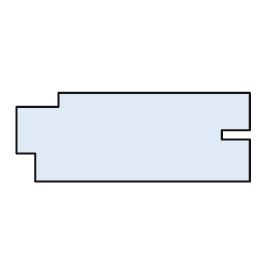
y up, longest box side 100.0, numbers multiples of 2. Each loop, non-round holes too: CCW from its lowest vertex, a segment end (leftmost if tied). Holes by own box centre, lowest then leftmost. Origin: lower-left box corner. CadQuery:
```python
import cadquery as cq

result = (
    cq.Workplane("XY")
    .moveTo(8.0, 0.0)
    .lineTo(100.0, 0.0)
    .lineTo(100.0, 18.0)
    .lineTo(88.0, 18.0)
    .lineTo(88.0, 22.0)
    .lineTo(100.0, 22.0)
    .lineTo(100.0, 38.0)
    .lineTo(18.0, 38.0)
    .lineTo(18.0, 32.0)
    .lineTo(0.0, 32.0)
    .lineTo(0.0, 12.0)
    .lineTo(8.0, 12.0)
    .close()
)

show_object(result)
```